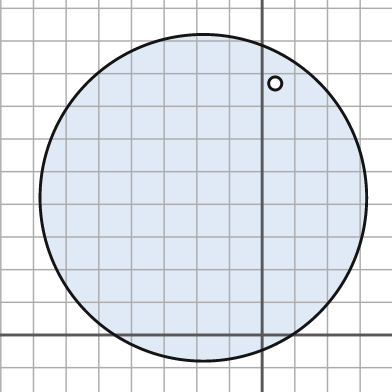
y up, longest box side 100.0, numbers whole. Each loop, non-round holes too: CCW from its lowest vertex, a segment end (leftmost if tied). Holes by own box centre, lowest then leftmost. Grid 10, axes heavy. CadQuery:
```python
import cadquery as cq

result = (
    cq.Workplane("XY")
    .moveTo(-18.0, 42.0)
    .circle(50.0)
    .moveTo(4.0, 77.0)
    .circle(2.0)
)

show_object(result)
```